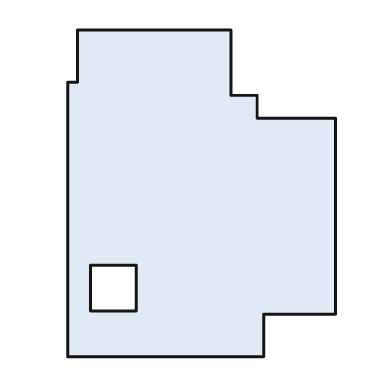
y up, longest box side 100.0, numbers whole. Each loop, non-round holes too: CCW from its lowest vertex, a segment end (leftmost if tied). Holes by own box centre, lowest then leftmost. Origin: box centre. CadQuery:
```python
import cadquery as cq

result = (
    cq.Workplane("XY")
    .moveTo(-41.0, -50.0)
    .lineTo(19.0, -50.0)
    .lineTo(19.0, -37.0)
    .lineTo(41.0, -37.0)
    .lineTo(41.0, 23.0)
    .lineTo(17.0, 23.0)
    .lineTo(17.0, 30.0)
    .lineTo(9.0, 30.0)
    .lineTo(9.0, 50.0)
    .lineTo(-38.0, 50.0)
    .lineTo(-38.0, 34.0)
    .lineTo(-41.0, 34.0)
    .close()
    .moveTo(-34.0, -36.0)
    .lineTo(-20.0, -36.0)
    .lineTo(-20.0, -22.0)
    .lineTo(-34.0, -22.0)
    .close()
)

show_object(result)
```